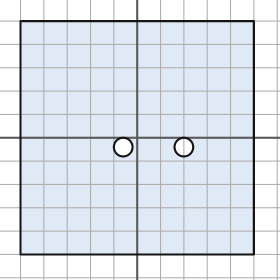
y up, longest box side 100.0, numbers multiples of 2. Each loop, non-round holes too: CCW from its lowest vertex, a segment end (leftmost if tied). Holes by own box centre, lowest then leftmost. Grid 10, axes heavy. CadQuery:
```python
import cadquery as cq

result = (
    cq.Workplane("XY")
    .moveTo(-50.0, -50.0)
    .lineTo(50.0, -50.0)
    .lineTo(50.0, 50.0)
    .lineTo(-50.0, 50.0)
    .close()
    .moveTo(-6.0, -4.0)
    .circle(4.0)
    .moveTo(20.0, -4.0)
    .circle(4.0)
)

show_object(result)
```